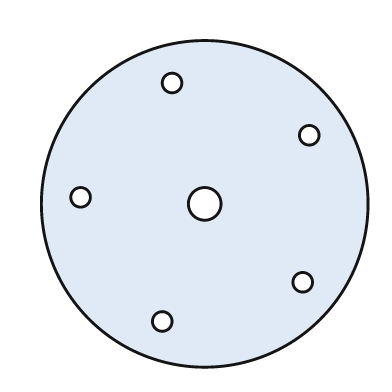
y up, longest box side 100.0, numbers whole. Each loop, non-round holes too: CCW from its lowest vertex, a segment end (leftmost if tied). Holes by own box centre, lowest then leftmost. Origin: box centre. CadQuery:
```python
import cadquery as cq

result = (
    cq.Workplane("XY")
    .moveTo(0.0, 0.0)
    .circle(50.0)
    .moveTo(-13.0, -36.0)
    .circle(3.0)
    .moveTo(30.0, -24.0)
    .circle(3.0)
    .moveTo(0.0, 0.0)
    .circle(5.0)
    .moveTo(-38.0, 2.0)
    .circle(3.0)
    .moveTo(32.0, 21.0)
    .circle(3.0)
    .moveTo(-10.0, 37.0)
    .circle(3.0)
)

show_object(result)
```